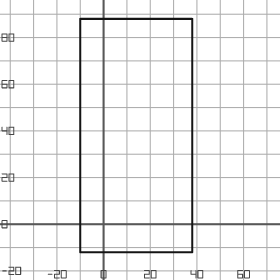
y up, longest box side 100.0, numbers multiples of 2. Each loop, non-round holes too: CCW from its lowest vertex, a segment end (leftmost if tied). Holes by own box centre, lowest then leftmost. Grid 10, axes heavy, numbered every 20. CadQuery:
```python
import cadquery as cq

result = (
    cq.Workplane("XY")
    .moveTo(-10.0, -12.0)
    .lineTo(38.0, -12.0)
    .lineTo(38.0, 88.0)
    .lineTo(-10.0, 88.0)
    .close()
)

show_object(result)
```